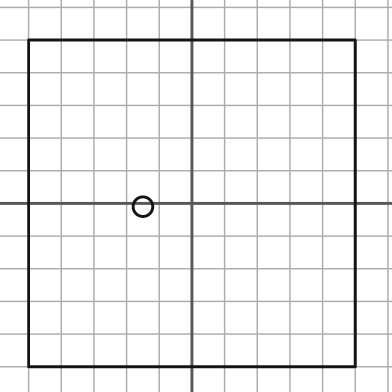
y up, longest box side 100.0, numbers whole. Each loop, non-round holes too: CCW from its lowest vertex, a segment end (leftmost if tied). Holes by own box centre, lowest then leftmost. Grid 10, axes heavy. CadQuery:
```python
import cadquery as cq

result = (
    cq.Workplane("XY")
    .moveTo(-50.0, -50.0)
    .lineTo(50.0, -50.0)
    .lineTo(50.0, 50.0)
    .lineTo(-50.0, 50.0)
    .close()
    .moveTo(-15.0, -1.0)
    .circle(3.0)
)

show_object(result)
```